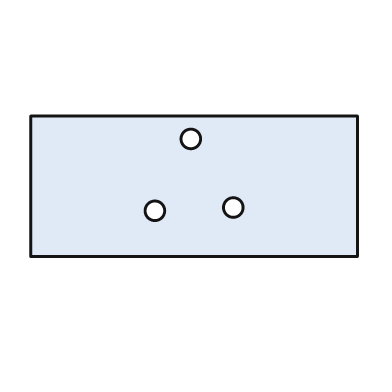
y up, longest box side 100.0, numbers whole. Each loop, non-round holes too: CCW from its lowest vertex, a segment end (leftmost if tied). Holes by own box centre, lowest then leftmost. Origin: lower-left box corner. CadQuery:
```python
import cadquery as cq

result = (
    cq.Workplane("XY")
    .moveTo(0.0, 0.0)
    .lineTo(100.0, 0.0)
    .lineTo(100.0, 43.0)
    .lineTo(0.0, 43.0)
    .close()
    .moveTo(38.0, 14.0)
    .circle(3.0)
    .moveTo(62.0, 15.0)
    .circle(3.0)
    .moveTo(49.0, 36.0)
    .circle(3.0)
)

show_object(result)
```